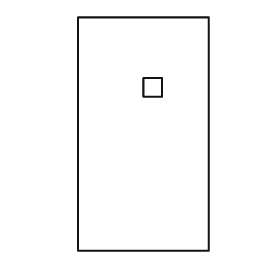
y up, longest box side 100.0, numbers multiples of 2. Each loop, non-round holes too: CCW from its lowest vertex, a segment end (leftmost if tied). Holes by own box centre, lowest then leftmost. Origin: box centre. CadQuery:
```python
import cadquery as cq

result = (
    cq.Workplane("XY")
    .moveTo(-28.0, -50.0)
    .lineTo(28.0, -50.0)
    .lineTo(28.0, 50.0)
    .lineTo(-28.0, 50.0)
    .close()
    .moveTo(0.0, 16.0)
    .lineTo(8.0, 16.0)
    .lineTo(8.0, 24.0)
    .lineTo(0.0, 24.0)
    .close()
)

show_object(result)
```